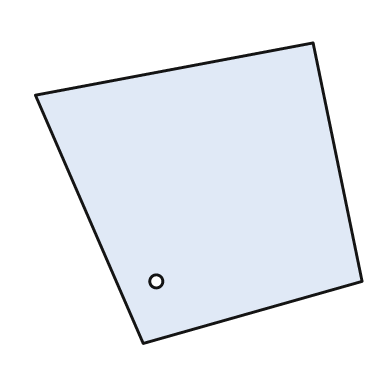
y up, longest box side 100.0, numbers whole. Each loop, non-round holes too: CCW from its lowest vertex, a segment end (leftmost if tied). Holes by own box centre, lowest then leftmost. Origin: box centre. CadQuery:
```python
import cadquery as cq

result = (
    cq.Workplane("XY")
    .moveTo(-17.0, -46.0)
    .lineTo(50.0, -27.0)
    .lineTo(35.0, 46.0)
    .lineTo(-50.0, 30.0)
    .close()
    .moveTo(-13.0, -27.0)
    .circle(2.0)
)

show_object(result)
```